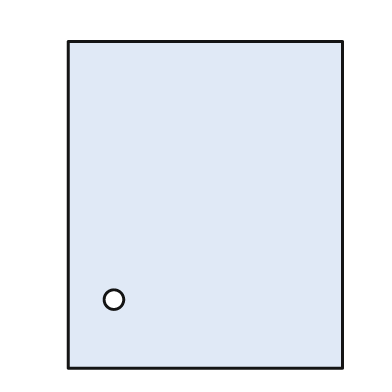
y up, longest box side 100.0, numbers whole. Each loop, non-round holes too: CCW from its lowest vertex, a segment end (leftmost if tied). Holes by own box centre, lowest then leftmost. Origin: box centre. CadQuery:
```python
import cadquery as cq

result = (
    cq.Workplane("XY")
    .moveTo(-42.0, -50.0)
    .lineTo(42.0, -50.0)
    .lineTo(42.0, 50.0)
    .lineTo(-42.0, 50.0)
    .close()
    .moveTo(-28.0, -29.0)
    .circle(3.0)
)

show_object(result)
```